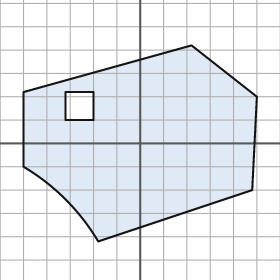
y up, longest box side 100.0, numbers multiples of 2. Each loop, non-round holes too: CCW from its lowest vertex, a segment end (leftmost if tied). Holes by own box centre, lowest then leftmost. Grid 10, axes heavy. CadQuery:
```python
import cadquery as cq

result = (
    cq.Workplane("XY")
    .moveTo(-18.0, -42.0)
    .lineTo(48.0, -20.0)
    .lineTo(50.0, 20.0)
    .lineTo(22.0, 42.0)
    .lineTo(-50.0, 22.0)
    .lineTo(-50.0, -10.0)
    .threePointArc((-32.0, -24.0), (-18.0, -42.0))
    .close()
    .moveTo(-32.0, 10.0)
    .lineTo(-20.0, 10.0)
    .lineTo(-20.0, 22.0)
    .lineTo(-32.0, 22.0)
    .close()
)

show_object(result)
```